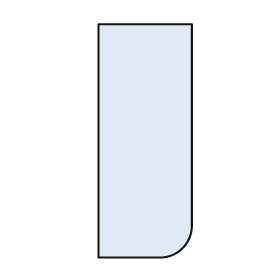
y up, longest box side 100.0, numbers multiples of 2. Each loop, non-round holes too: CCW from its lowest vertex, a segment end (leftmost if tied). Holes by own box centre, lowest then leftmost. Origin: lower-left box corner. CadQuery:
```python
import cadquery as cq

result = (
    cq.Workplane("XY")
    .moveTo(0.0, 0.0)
    .lineTo(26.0, 0.0)
    .threePointArc((36.0, 4.0), (40.0, 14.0))
    .lineTo(40.0, 100.0)
    .lineTo(0.0, 100.0)
    .close()
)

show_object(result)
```